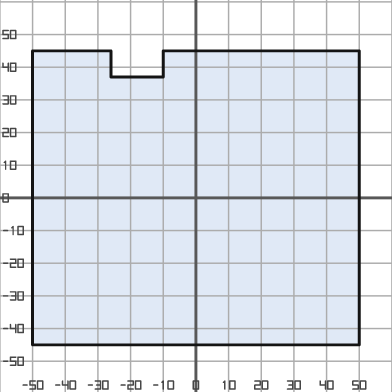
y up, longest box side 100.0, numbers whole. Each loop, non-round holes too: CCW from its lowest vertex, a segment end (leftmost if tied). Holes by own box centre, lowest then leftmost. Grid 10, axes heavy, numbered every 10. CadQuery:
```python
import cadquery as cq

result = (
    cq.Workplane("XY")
    .moveTo(-50.0, -45.0)
    .lineTo(50.0, -45.0)
    .lineTo(50.0, 45.0)
    .lineTo(-10.0, 45.0)
    .lineTo(-10.0, 37.0)
    .lineTo(-26.0, 37.0)
    .lineTo(-26.0, 45.0)
    .lineTo(-50.0, 45.0)
    .close()
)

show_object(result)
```